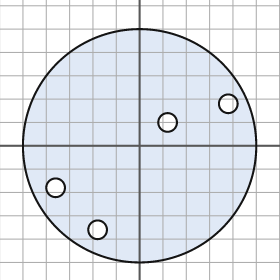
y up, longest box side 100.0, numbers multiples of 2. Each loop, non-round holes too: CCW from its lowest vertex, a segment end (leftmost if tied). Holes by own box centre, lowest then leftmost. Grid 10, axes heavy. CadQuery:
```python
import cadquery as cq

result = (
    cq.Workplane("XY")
    .moveTo(0.0, 0.0)
    .circle(50.0)
    .moveTo(-18.0, -36.0)
    .circle(4.0)
    .moveTo(-36.0, -18.0)
    .circle(4.0)
    .moveTo(12.0, 10.0)
    .circle(4.0)
    .moveTo(38.0, 18.0)
    .circle(4.0)
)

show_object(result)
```